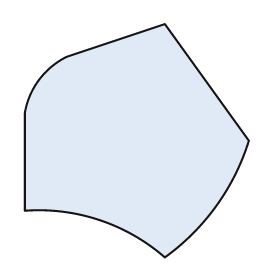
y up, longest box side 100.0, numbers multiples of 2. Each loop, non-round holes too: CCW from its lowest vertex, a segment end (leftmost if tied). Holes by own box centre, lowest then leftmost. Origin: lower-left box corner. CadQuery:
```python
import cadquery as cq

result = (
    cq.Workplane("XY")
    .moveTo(60.0, 0.0)
    .threePointArc((82.0, 22.0), (96.0, 50.0))
    .lineTo(60.0, 100.0)
    .lineTo(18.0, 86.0)
    .threePointArc((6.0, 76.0), (0.0, 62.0))
    .lineTo(0.0, 20.0)
    .threePointArc((32.0, 16.0), (60.0, 0.0))
    .close()
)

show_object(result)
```